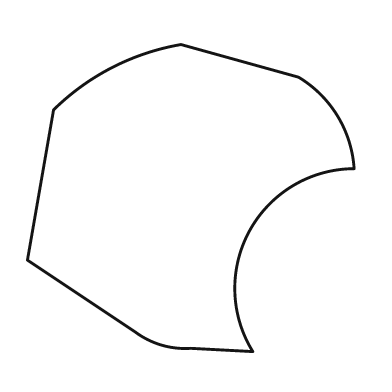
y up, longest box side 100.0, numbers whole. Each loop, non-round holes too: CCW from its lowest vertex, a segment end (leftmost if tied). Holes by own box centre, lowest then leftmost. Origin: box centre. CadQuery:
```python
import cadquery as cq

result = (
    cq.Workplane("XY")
    .moveTo(19.0, -47.0)
    .threePointArc((18.0, -10.0), (50.0, 9.0))
    .threePointArc((45.0, 25.0), (33.0, 37.0))
    .lineTo(-3.0, 47.0)
    .threePointArc((-24.0, 40.0), (-42.0, 27.0))
    .lineTo(-50.0, -19.0)
    .lineTo(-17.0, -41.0)
    .threePointArc((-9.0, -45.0), (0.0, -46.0))
    .close()
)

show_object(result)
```